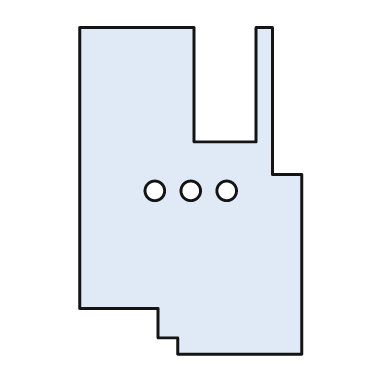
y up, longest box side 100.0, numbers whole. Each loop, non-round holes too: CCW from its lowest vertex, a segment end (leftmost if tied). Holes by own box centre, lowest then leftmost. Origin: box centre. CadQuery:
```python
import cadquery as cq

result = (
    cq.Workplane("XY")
    .moveTo(-4.0, -50.0)
    .lineTo(34.0, -50.0)
    .lineTo(34.0, 5.0)
    .lineTo(25.0, 5.0)
    .lineTo(25.0, 50.0)
    .lineTo(20.0, 50.0)
    .lineTo(20.0, 15.0)
    .lineTo(1.0, 15.0)
    .lineTo(1.0, 50.0)
    .lineTo(-34.0, 50.0)
    .lineTo(-34.0, -36.0)
    .lineTo(-10.0, -36.0)
    .lineTo(-10.0, -45.0)
    .lineTo(-4.0, -45.0)
    .close()
    .moveTo(-11.0, 0.0)
    .circle(3.0)
    .moveTo(0.0, 0.0)
    .circle(3.0)
    .moveTo(11.0, 0.0)
    .circle(3.0)
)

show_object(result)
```